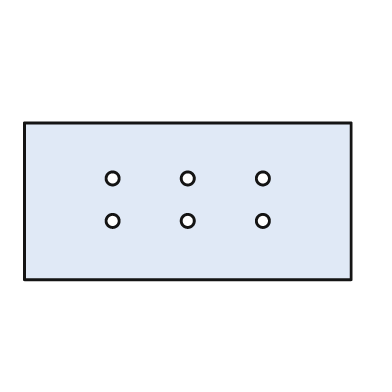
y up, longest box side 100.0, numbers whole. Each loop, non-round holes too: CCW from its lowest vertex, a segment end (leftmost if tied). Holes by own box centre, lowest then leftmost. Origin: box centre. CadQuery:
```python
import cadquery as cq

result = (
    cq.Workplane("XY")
    .moveTo(-50.0, -24.0)
    .lineTo(50.0, -24.0)
    .lineTo(50.0, 24.0)
    .lineTo(-50.0, 24.0)
    .close()
    .moveTo(-23.0, -6.0)
    .circle(2.0)
    .moveTo(0.0, -6.0)
    .circle(2.0)
    .moveTo(23.0, -6.0)
    .circle(2.0)
    .moveTo(-23.0, 7.0)
    .circle(2.0)
    .moveTo(0.0, 7.0)
    .circle(2.0)
    .moveTo(23.0, 7.0)
    .circle(2.0)
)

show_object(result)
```